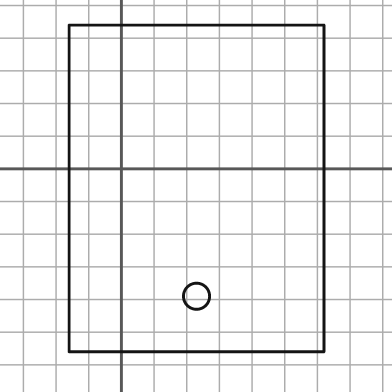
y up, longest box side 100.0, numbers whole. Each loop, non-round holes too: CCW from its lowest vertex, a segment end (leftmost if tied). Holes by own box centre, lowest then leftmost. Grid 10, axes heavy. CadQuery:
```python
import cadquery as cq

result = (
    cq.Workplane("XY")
    .moveTo(-16.0, -56.0)
    .lineTo(62.0, -56.0)
    .lineTo(62.0, 44.0)
    .lineTo(-16.0, 44.0)
    .close()
    .moveTo(23.0, -39.0)
    .circle(4.0)
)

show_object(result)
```